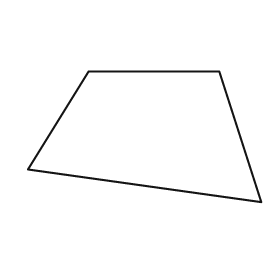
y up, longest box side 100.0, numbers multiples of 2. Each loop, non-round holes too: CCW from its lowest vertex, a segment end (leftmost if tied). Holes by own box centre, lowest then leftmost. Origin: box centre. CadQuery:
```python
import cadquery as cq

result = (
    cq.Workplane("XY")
    .moveTo(50.0, -28.0)
    .lineTo(32.0, 28.0)
    .lineTo(-24.0, 28.0)
    .lineTo(-50.0, -14.0)
    .close()
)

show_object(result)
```